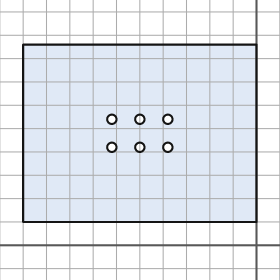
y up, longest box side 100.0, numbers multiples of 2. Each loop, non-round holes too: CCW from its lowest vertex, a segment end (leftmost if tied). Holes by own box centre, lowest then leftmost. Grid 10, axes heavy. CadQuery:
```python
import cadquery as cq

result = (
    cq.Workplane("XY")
    .moveTo(-100.0, 10.0)
    .lineTo(0.0, 10.0)
    .lineTo(0.0, 86.0)
    .lineTo(-100.0, 86.0)
    .close()
    .moveTo(-62.0, 42.0)
    .circle(2.0)
    .moveTo(-50.0, 42.0)
    .circle(2.0)
    .moveTo(-38.0, 42.0)
    .circle(2.0)
    .moveTo(-62.0, 54.0)
    .circle(2.0)
    .moveTo(-50.0, 54.0)
    .circle(2.0)
    .moveTo(-38.0, 54.0)
    .circle(2.0)
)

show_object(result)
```